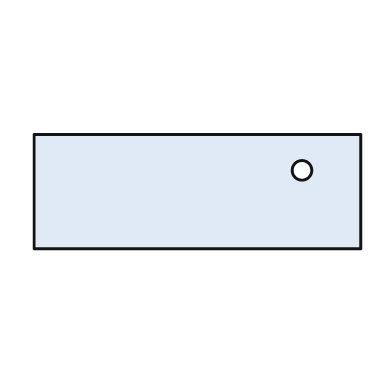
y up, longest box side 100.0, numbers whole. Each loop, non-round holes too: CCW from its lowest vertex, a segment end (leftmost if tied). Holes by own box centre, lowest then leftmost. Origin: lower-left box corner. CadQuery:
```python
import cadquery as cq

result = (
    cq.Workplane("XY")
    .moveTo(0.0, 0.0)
    .lineTo(100.0, 0.0)
    .lineTo(100.0, 35.0)
    .lineTo(0.0, 35.0)
    .close()
    .moveTo(82.0, 24.0)
    .circle(3.0)
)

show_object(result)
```